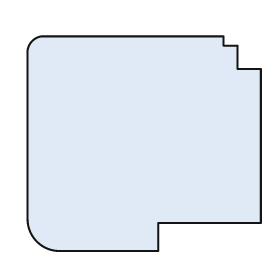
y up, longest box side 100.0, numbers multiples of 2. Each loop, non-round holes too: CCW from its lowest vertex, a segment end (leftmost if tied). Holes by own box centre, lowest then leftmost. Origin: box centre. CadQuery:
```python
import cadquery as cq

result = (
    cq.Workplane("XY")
    .moveTo(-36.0, -46.0)
    .lineTo(6.0, -46.0)
    .lineTo(6.0, -34.0)
    .lineTo(50.0, -34.0)
    .lineTo(50.0, 32.0)
    .lineTo(40.0, 32.0)
    .lineTo(40.0, 42.0)
    .lineTo(34.0, 42.0)
    .lineTo(34.0, 46.0)
    .lineTo(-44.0, 46.0)
    .threePointArc((-48.0, 44.0), (-50.0, 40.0))
    .lineTo(-50.0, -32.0)
    .threePointArc((-46.0, -42.0), (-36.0, -46.0))
    .close()
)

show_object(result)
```